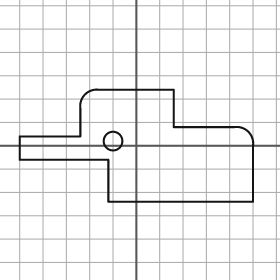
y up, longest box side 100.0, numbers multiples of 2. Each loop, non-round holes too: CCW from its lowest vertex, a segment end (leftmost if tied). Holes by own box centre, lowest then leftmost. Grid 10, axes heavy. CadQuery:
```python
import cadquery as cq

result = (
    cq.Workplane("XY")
    .moveTo(-12.0, -24.0)
    .lineTo(50.0, -24.0)
    .lineTo(50.0, 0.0)
    .threePointArc((48.0, 6.0), (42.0, 8.0))
    .lineTo(16.0, 8.0)
    .lineTo(16.0, 24.0)
    .lineTo(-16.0, 24.0)
    .threePointArc((-22.0, 22.0), (-24.0, 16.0))
    .lineTo(-24.0, 4.0)
    .lineTo(-50.0, 4.0)
    .lineTo(-50.0, -6.0)
    .lineTo(-12.0, -6.0)
    .close()
    .moveTo(-10.0, 2.0)
    .circle(4.0)
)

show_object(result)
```